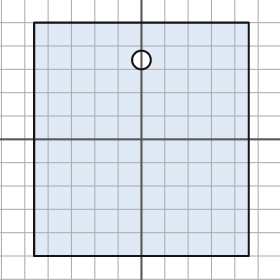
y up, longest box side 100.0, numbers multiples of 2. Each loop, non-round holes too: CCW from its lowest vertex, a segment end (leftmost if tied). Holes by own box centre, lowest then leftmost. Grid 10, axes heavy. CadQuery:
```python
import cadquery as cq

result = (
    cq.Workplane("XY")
    .moveTo(-46.0, -50.0)
    .lineTo(46.0, -50.0)
    .lineTo(46.0, 50.0)
    .lineTo(-46.0, 50.0)
    .close()
    .moveTo(0.0, 34.0)
    .circle(4.0)
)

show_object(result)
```